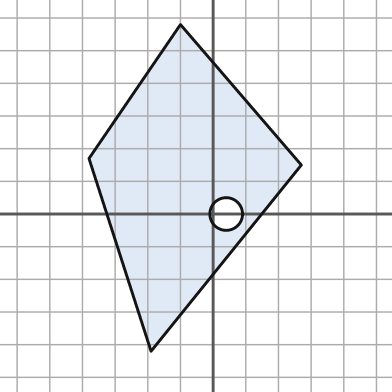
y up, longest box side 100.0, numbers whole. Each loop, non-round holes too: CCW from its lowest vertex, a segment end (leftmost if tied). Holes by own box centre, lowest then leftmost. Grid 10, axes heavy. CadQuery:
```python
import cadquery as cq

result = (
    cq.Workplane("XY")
    .moveTo(-19.0, -42.0)
    .lineTo(27.0, 15.0)
    .lineTo(-10.0, 58.0)
    .lineTo(-38.0, 17.0)
    .close()
    .moveTo(4.0, 0.0)
    .circle(5.0)
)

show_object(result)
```